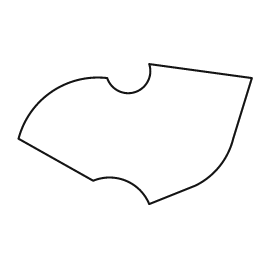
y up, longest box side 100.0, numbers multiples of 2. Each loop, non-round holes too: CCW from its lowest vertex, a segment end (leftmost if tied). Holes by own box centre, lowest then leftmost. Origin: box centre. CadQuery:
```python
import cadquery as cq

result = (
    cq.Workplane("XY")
    .moveTo(6.0, -30.0)
    .lineTo(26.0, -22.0)
    .threePointArc((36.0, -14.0), (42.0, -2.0))
    .lineTo(50.0, 24.0)
    .lineTo(6.0, 30.0)
    .threePointArc((0.0, 18.0), (-12.0, 24.0))
    .threePointArc((-36.0, 18.0), (-50.0, -2.0))
    .lineTo(-18.0, -20.0)
    .threePointArc((-4.0, -20.0), (6.0, -30.0))
    .close()
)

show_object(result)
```